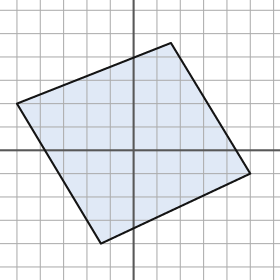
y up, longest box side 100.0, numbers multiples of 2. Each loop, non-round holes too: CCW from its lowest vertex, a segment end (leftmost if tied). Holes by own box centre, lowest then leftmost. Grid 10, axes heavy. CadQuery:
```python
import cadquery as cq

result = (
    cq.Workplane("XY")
    .moveTo(-14.0, -40.0)
    .lineTo(50.0, -10.0)
    .lineTo(16.0, 46.0)
    .lineTo(-50.0, 20.0)
    .close()
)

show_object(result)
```